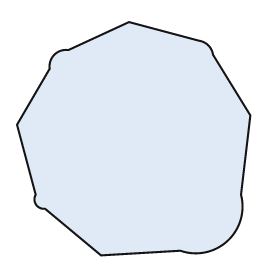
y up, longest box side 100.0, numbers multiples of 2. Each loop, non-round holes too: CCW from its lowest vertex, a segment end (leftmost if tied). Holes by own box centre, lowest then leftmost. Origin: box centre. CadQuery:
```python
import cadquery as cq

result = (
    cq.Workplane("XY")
    .moveTo(-14.0, -50.0)
    .lineTo(20.0, -48.0)
    .threePointArc((40.0, -44.0), (46.0, -24.0))
    .lineTo(50.0, 10.0)
    .lineTo(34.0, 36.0)
    .threePointArc((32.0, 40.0), (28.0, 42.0))
    .lineTo(-2.0, 50.0)
    .lineTo(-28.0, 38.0)
    .threePointArc((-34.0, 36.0), (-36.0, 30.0))
    .lineTo(-50.0, 6.0)
    .lineTo(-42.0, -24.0)
    .threePointArc((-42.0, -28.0), (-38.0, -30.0))
    .close()
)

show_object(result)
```